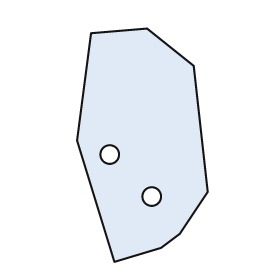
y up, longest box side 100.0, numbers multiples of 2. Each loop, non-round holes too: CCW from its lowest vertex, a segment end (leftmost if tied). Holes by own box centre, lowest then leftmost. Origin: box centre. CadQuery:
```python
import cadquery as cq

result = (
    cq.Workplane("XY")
    .moveTo(-12.0, -50.0)
    .lineTo(8.0, -44.0)
    .lineTo(16.0, -38.0)
    .lineTo(28.0, -20.0)
    .lineTo(22.0, 34.0)
    .lineTo(2.0, 50.0)
    .lineTo(-22.0, 48.0)
    .lineTo(-28.0, 2.0)
    .close()
    .moveTo(4.0, -22.0)
    .circle(4.0)
    .moveTo(-14.0, -4.0)
    .circle(4.0)
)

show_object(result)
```